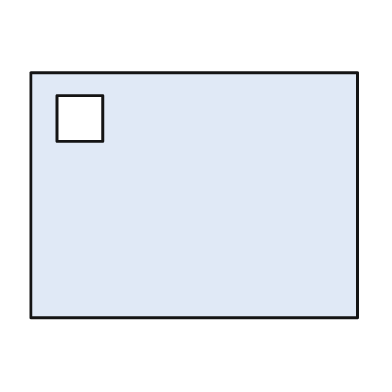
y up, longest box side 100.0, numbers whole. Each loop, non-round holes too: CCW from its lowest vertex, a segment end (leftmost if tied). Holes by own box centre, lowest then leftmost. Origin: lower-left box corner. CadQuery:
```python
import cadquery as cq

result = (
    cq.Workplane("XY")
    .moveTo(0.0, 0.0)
    .lineTo(100.0, 0.0)
    .lineTo(100.0, 75.0)
    .lineTo(0.0, 75.0)
    .close()
    .moveTo(8.0, 54.0)
    .lineTo(22.0, 54.0)
    .lineTo(22.0, 68.0)
    .lineTo(8.0, 68.0)
    .close()
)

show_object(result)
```